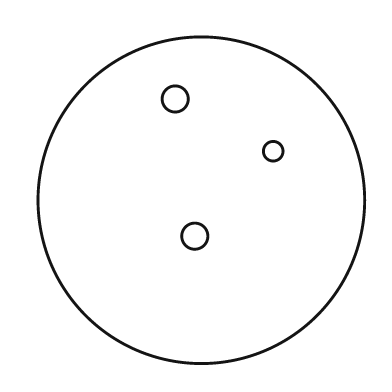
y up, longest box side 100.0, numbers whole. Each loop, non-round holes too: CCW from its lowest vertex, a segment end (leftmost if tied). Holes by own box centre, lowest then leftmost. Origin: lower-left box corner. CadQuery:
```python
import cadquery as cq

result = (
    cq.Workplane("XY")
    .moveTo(50.0, 50.0)
    .circle(50.0)
    .moveTo(48.0, 39.0)
    .circle(4.0)
    .moveTo(72.0, 65.0)
    .circle(3.0)
    .moveTo(42.0, 81.0)
    .circle(4.0)
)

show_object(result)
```